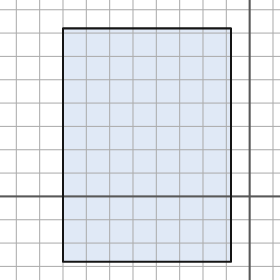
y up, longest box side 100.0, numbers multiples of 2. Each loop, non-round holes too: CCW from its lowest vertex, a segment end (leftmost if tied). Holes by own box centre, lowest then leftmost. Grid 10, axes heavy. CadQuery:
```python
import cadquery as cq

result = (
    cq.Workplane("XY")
    .moveTo(-80.0, -28.0)
    .lineTo(-8.0, -28.0)
    .lineTo(-8.0, 72.0)
    .lineTo(-80.0, 72.0)
    .close()
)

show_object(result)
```